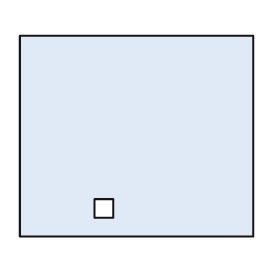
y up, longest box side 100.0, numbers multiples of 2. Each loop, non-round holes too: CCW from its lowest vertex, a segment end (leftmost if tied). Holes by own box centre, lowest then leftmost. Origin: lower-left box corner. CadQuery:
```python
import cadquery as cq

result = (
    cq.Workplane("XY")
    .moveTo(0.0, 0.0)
    .lineTo(100.0, 0.0)
    .lineTo(100.0, 86.0)
    .lineTo(0.0, 86.0)
    .close()
    .moveTo(32.0, 8.0)
    .lineTo(40.0, 8.0)
    .lineTo(40.0, 16.0)
    .lineTo(32.0, 16.0)
    .close()
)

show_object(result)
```